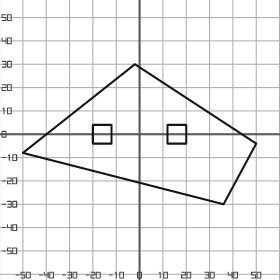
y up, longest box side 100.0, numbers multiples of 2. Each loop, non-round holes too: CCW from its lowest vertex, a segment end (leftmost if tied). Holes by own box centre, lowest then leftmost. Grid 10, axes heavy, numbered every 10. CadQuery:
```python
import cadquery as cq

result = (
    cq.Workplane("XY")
    .moveTo(36.0, -30.0)
    .lineTo(50.0, -4.0)
    .lineTo(-2.0, 30.0)
    .lineTo(-50.0, -8.0)
    .close()
    .moveTo(-20.0, -4.0)
    .lineTo(-12.0, -4.0)
    .lineTo(-12.0, 4.0)
    .lineTo(-20.0, 4.0)
    .close()
    .moveTo(12.0, -4.0)
    .lineTo(20.0, -4.0)
    .lineTo(20.0, 4.0)
    .lineTo(12.0, 4.0)
    .close()
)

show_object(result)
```